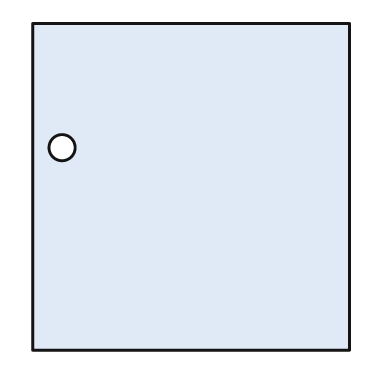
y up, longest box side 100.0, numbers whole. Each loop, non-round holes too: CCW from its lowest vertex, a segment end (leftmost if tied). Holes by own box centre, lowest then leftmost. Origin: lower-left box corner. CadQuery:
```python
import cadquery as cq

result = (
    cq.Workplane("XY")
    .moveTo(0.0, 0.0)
    .lineTo(97.0, 0.0)
    .lineTo(97.0, 100.0)
    .lineTo(0.0, 100.0)
    .close()
    .moveTo(9.0, 62.0)
    .circle(4.0)
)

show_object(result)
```